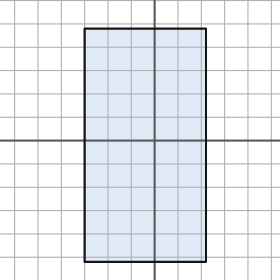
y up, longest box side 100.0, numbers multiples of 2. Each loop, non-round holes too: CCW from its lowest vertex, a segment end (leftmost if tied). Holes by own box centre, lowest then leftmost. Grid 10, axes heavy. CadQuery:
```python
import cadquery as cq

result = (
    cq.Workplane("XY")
    .moveTo(-30.0, -52.0)
    .lineTo(22.0, -52.0)
    .lineTo(22.0, 48.0)
    .lineTo(-30.0, 48.0)
    .close()
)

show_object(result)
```